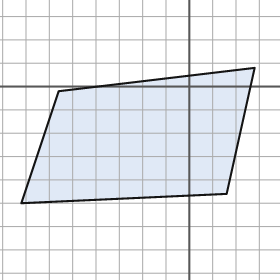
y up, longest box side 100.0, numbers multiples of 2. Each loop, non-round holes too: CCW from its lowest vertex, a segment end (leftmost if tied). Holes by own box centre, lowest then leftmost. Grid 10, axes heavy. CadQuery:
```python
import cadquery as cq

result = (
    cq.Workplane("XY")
    .moveTo(-72.0, -50.0)
    .lineTo(16.0, -46.0)
    .lineTo(28.0, 8.0)
    .lineTo(-56.0, -2.0)
    .close()
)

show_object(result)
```